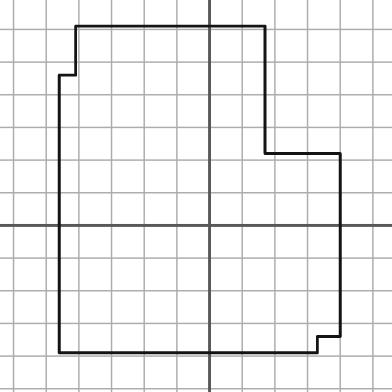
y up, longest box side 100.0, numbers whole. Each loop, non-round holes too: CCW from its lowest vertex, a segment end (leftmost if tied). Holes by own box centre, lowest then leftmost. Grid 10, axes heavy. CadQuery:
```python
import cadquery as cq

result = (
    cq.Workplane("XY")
    .moveTo(-46.0, -39.0)
    .lineTo(33.0, -39.0)
    .lineTo(33.0, -34.0)
    .lineTo(40.0, -34.0)
    .lineTo(40.0, 22.0)
    .lineTo(17.0, 22.0)
    .lineTo(17.0, 61.0)
    .lineTo(-41.0, 61.0)
    .lineTo(-41.0, 46.0)
    .lineTo(-46.0, 46.0)
    .close()
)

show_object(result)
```